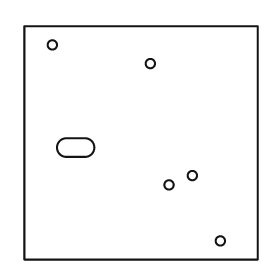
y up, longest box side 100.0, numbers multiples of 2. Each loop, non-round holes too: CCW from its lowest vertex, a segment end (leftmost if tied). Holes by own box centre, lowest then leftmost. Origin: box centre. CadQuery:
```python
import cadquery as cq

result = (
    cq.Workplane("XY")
    .moveTo(-50.0, -50.0)
    .lineTo(50.0, -50.0)
    .lineTo(50.0, 50.0)
    .lineTo(-50.0, 50.0)
    .close()
    .moveTo(34.0, -42.0)
    .circle(2.0)
    .moveTo(12.0, -18.0)
    .circle(2.0)
    .moveTo(22.0, -14.0)
    .circle(2.0)
    .moveTo(-32.0, -6.0)
    .lineTo(-24.0, -6.0)
    .threePointArc((-20.0, -2.0), (-24.0, 2.0))
    .lineTo(-32.0, 2.0)
    .threePointArc((-36.0, -2.0), (-32.0, -6.0))
    .close()
    .moveTo(4.0, 34.0)
    .circle(2.0)
    .moveTo(-38.0, 42.0)
    .circle(2.0)
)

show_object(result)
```